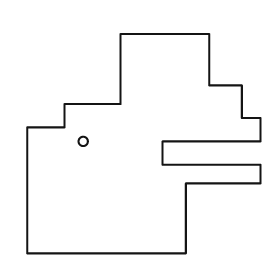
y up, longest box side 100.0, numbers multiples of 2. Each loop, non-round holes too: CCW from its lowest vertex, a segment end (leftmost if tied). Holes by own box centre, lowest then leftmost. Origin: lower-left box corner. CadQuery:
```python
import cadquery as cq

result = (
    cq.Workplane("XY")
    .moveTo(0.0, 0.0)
    .lineTo(68.0, 0.0)
    .lineTo(68.0, 30.0)
    .lineTo(100.0, 30.0)
    .lineTo(100.0, 38.0)
    .lineTo(58.0, 38.0)
    .lineTo(58.0, 48.0)
    .lineTo(100.0, 48.0)
    .lineTo(100.0, 58.0)
    .lineTo(92.0, 58.0)
    .lineTo(92.0, 72.0)
    .lineTo(78.0, 72.0)
    .lineTo(78.0, 94.0)
    .lineTo(40.0, 94.0)
    .lineTo(40.0, 64.0)
    .lineTo(16.0, 64.0)
    .lineTo(16.0, 54.0)
    .lineTo(0.0, 54.0)
    .close()
    .moveTo(24.0, 48.0)
    .circle(2.0)
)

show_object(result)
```